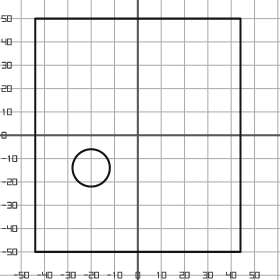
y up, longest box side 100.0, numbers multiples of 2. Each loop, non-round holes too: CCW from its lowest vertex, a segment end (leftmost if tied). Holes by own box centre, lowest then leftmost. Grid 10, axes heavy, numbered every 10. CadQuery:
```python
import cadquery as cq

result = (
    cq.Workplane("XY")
    .moveTo(-44.0, -50.0)
    .lineTo(44.0, -50.0)
    .lineTo(44.0, 50.0)
    .lineTo(-44.0, 50.0)
    .close()
    .moveTo(-20.0, -14.0)
    .circle(8.0)
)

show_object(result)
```